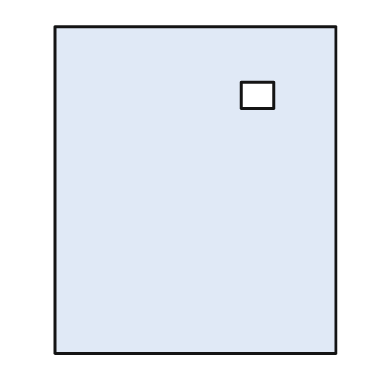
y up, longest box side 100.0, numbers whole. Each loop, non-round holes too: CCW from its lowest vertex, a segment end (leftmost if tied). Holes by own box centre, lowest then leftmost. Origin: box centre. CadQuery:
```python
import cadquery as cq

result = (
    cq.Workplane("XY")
    .moveTo(-43.0, -50.0)
    .lineTo(43.0, -50.0)
    .lineTo(43.0, 50.0)
    .lineTo(-43.0, 50.0)
    .close()
    .moveTo(14.0, 25.0)
    .lineTo(24.0, 25.0)
    .lineTo(24.0, 33.0)
    .lineTo(14.0, 33.0)
    .close()
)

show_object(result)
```